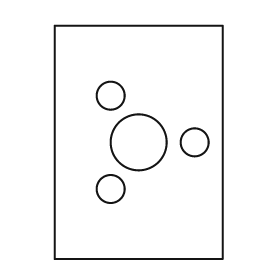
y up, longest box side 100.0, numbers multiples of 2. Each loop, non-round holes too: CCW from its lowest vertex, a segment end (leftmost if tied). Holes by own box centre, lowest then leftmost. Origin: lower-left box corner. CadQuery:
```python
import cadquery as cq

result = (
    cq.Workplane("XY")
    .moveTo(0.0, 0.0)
    .lineTo(72.0, 0.0)
    .lineTo(72.0, 100.0)
    .lineTo(0.0, 100.0)
    .close()
    .moveTo(24.0, 30.0)
    .circle(6.0)
    .moveTo(36.0, 50.0)
    .circle(12.0)
    .moveTo(60.0, 50.0)
    .circle(6.0)
    .moveTo(24.0, 70.0)
    .circle(6.0)
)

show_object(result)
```